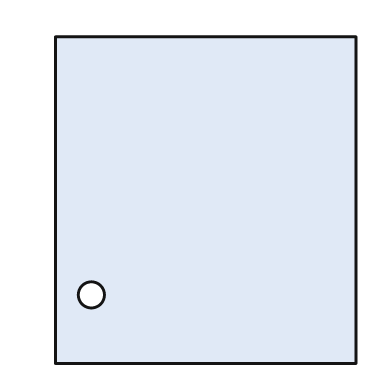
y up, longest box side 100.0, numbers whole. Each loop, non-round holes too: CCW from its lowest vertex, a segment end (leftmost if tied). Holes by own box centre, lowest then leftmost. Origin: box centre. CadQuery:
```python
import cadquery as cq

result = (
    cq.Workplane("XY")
    .moveTo(-46.0, -50.0)
    .lineTo(46.0, -50.0)
    .lineTo(46.0, 50.0)
    .lineTo(-46.0, 50.0)
    .close()
    .moveTo(-35.0, -29.0)
    .circle(4.0)
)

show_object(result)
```